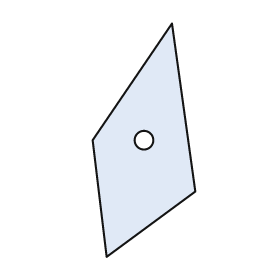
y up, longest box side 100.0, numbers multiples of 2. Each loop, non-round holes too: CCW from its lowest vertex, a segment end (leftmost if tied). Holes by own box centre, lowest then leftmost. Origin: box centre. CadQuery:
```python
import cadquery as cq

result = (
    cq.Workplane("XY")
    .moveTo(-16.0, -50.0)
    .lineTo(22.0, -22.0)
    .lineTo(12.0, 50.0)
    .lineTo(-22.0, 0.0)
    .close()
    .moveTo(0.0, 0.0)
    .circle(4.0)
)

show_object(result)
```